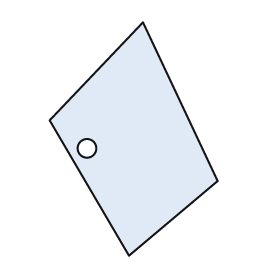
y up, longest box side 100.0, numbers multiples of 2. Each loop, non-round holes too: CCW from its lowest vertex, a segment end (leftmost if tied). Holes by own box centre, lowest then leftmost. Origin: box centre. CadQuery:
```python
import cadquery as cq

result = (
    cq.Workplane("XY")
    .moveTo(-2.0, -50.0)
    .lineTo(36.0, -18.0)
    .lineTo(4.0, 50.0)
    .lineTo(-36.0, 8.0)
    .close()
    .moveTo(-20.0, -4.0)
    .circle(4.0)
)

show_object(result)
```